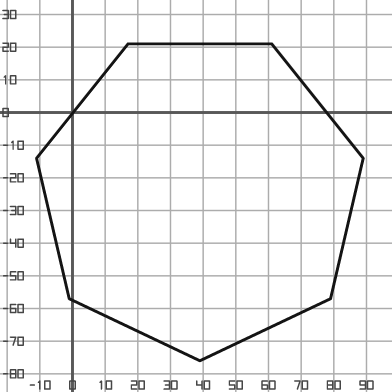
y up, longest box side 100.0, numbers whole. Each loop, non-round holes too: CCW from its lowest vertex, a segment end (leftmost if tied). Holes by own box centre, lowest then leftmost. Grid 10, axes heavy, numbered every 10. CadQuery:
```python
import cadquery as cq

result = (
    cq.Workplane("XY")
    .moveTo(39.0, -76.0)
    .lineTo(79.0, -57.0)
    .lineTo(89.0, -14.0)
    .lineTo(61.0, 21.0)
    .lineTo(17.0, 21.0)
    .lineTo(-11.0, -14.0)
    .lineTo(-1.0, -57.0)
    .close()
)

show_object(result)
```